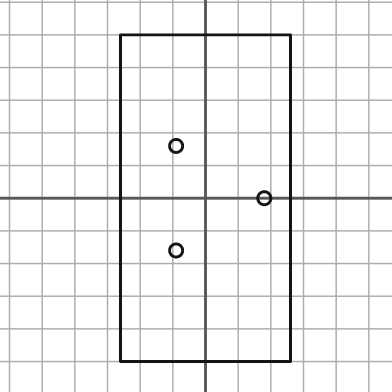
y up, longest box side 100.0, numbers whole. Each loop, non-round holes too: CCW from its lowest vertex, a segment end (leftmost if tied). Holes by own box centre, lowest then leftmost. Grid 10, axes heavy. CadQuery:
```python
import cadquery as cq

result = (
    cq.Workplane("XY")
    .moveTo(-26.0, -50.0)
    .lineTo(26.0, -50.0)
    .lineTo(26.0, 50.0)
    .lineTo(-26.0, 50.0)
    .close()
    .moveTo(-9.0, -16.0)
    .circle(2.0)
    .moveTo(18.0, 0.0)
    .circle(2.0)
    .moveTo(-9.0, 16.0)
    .circle(2.0)
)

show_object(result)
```